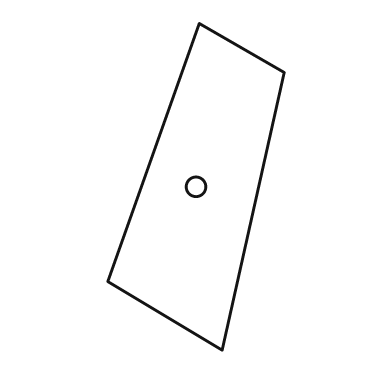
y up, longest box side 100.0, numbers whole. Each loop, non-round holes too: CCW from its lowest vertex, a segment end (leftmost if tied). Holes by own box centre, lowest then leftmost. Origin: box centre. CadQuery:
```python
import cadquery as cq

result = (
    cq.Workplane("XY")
    .moveTo(8.0, -50.0)
    .lineTo(27.0, 35.0)
    .lineTo(1.0, 50.0)
    .lineTo(-27.0, -29.0)
    .close()
    .moveTo(0.0, 0.0)
    .circle(3.0)
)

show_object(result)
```